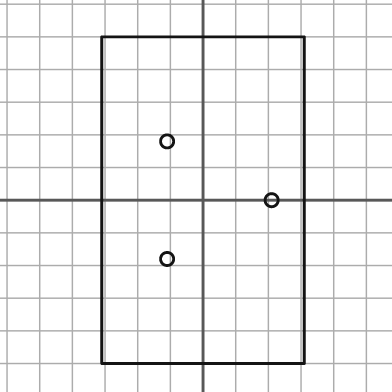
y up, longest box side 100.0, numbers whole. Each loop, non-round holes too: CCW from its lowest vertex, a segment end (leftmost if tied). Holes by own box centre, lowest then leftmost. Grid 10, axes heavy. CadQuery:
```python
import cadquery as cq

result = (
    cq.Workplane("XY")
    .moveTo(-31.0, -50.0)
    .lineTo(31.0, -50.0)
    .lineTo(31.0, 50.0)
    .lineTo(-31.0, 50.0)
    .close()
    .moveTo(-11.0, -18.0)
    .circle(2.0)
    .moveTo(21.0, 0.0)
    .circle(2.0)
    .moveTo(-11.0, 18.0)
    .circle(2.0)
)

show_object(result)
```